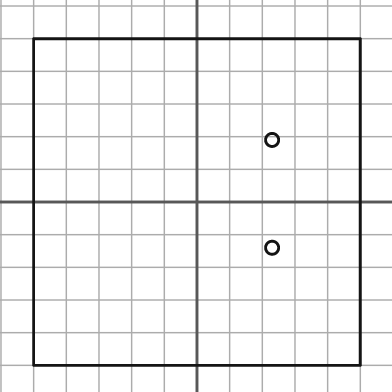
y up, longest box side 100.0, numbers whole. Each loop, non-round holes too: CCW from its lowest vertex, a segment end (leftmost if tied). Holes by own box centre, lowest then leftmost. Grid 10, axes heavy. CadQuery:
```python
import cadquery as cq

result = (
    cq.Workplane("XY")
    .moveTo(-50.0, -50.0)
    .lineTo(50.0, -50.0)
    .lineTo(50.0, 50.0)
    .lineTo(-50.0, 50.0)
    .close()
    .moveTo(23.0, -14.0)
    .circle(2.0)
    .moveTo(23.0, 19.0)
    .circle(2.0)
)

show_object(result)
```